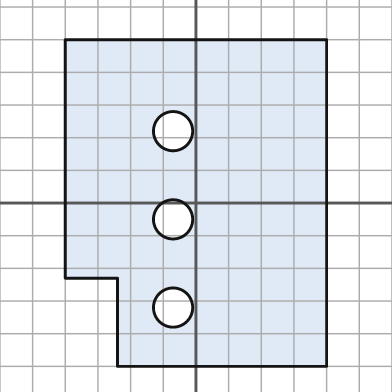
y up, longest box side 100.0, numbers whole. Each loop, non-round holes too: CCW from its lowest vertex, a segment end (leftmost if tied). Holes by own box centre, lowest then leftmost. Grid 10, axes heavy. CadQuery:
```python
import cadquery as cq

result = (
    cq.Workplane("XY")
    .moveTo(-24.0, -50.0)
    .lineTo(40.0, -50.0)
    .lineTo(40.0, 50.0)
    .lineTo(-40.0, 50.0)
    .lineTo(-40.0, -23.0)
    .lineTo(-24.0, -23.0)
    .close()
    .moveTo(-7.0, -32.0)
    .circle(6.0)
    .moveTo(-7.0, -5.0)
    .circle(6.0)
    .moveTo(-7.0, 22.0)
    .circle(6.0)
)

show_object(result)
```